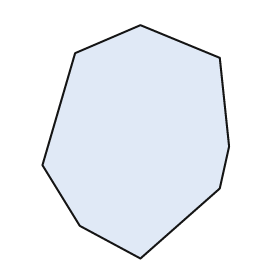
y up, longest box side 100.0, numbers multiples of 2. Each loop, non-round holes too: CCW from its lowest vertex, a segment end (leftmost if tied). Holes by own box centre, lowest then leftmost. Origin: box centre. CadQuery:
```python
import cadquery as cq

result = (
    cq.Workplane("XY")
    .moveTo(2.0, -50.0)
    .lineTo(36.0, -20.0)
    .lineTo(40.0, -2.0)
    .lineTo(36.0, 36.0)
    .lineTo(2.0, 50.0)
    .lineTo(-26.0, 38.0)
    .lineTo(-40.0, -10.0)
    .lineTo(-24.0, -36.0)
    .close()
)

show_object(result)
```